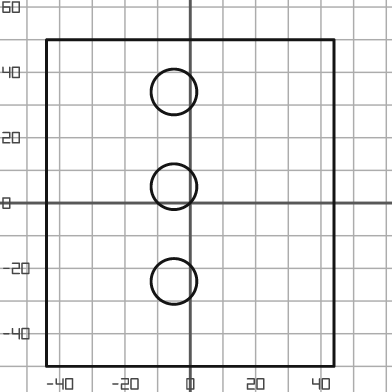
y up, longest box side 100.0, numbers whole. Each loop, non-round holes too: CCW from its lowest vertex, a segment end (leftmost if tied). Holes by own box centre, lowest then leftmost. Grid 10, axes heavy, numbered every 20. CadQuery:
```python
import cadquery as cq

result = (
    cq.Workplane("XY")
    .moveTo(-44.0, -50.0)
    .lineTo(44.0, -50.0)
    .lineTo(44.0, 50.0)
    .lineTo(-44.0, 50.0)
    .close()
    .moveTo(-5.0, -24.0)
    .circle(7.0)
    .moveTo(-5.0, 5.0)
    .circle(7.0)
    .moveTo(-5.0, 34.0)
    .circle(7.0)
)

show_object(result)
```